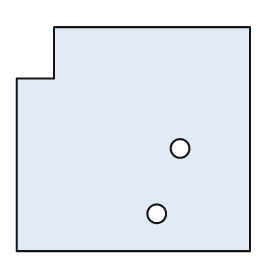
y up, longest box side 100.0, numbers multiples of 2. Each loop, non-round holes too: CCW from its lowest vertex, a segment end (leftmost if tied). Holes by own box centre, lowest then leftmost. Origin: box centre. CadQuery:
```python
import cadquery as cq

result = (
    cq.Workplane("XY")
    .moveTo(-50.0, -48.0)
    .lineTo(50.0, -48.0)
    .lineTo(50.0, 48.0)
    .lineTo(-34.0, 48.0)
    .lineTo(-34.0, 26.0)
    .lineTo(-50.0, 26.0)
    .close()
    .moveTo(10.0, -32.0)
    .circle(4.0)
    .moveTo(20.0, -4.0)
    .circle(4.0)
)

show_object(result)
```